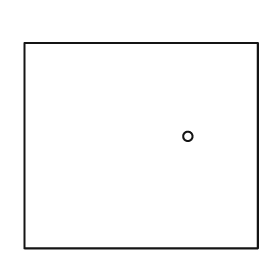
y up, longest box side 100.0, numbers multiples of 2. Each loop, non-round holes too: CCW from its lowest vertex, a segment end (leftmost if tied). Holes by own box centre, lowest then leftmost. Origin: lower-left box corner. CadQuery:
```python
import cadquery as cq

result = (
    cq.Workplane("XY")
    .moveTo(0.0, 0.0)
    .lineTo(100.0, 0.0)
    .lineTo(100.0, 88.0)
    .lineTo(0.0, 88.0)
    .close()
    .moveTo(70.0, 48.0)
    .circle(2.0)
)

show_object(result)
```